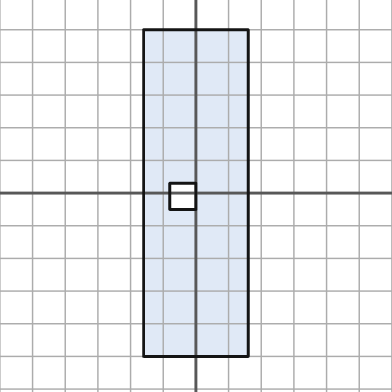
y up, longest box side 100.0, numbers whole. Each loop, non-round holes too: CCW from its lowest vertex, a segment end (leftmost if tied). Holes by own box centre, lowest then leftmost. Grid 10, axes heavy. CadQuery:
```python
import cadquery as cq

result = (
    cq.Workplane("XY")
    .moveTo(-16.0, -50.0)
    .lineTo(16.0, -50.0)
    .lineTo(16.0, 50.0)
    .lineTo(-16.0, 50.0)
    .close()
    .moveTo(-8.0, -5.0)
    .lineTo(0.0, -5.0)
    .lineTo(0.0, 3.0)
    .lineTo(-8.0, 3.0)
    .close()
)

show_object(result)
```